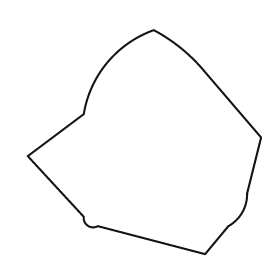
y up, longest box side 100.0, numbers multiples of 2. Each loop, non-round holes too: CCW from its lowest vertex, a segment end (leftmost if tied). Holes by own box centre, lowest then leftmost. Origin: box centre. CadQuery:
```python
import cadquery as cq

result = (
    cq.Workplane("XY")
    .moveTo(26.0, -48.0)
    .lineTo(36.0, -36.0)
    .threePointArc((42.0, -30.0), (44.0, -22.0))
    .lineTo(50.0, 2.0)
    .lineTo(26.0, 30.0)
    .threePointArc((16.0, 40.0), (4.0, 48.0))
    .threePointArc((-16.0, 34.0), (-26.0, 12.0))
    .lineTo(-50.0, -6.0)
    .lineTo(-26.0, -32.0)
    .threePointArc((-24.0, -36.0), (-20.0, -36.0))
    .close()
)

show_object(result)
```